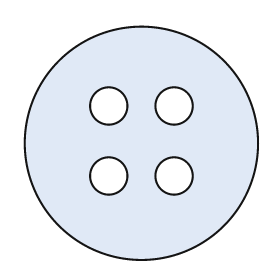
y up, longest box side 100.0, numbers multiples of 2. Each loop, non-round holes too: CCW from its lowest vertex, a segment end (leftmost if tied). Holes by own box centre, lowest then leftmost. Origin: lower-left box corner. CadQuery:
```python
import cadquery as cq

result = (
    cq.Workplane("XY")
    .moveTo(50.0, 50.0)
    .circle(50.0)
    .moveTo(36.0, 36.0)
    .circle(8.0)
    .moveTo(64.0, 36.0)
    .circle(8.0)
    .moveTo(36.0, 66.0)
    .circle(8.0)
    .moveTo(64.0, 66.0)
    .circle(8.0)
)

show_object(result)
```